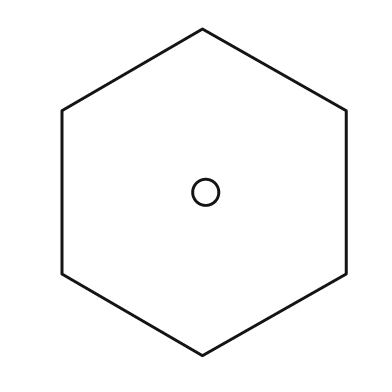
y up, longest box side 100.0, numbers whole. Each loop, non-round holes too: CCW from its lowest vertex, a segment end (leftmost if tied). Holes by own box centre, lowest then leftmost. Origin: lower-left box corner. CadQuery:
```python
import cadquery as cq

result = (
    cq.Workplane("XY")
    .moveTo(43.0, 0.0)
    .lineTo(87.0, 25.0)
    .lineTo(87.0, 75.0)
    .lineTo(43.0, 100.0)
    .lineTo(0.0, 75.0)
    .lineTo(0.0, 25.0)
    .close()
    .moveTo(44.0, 50.0)
    .circle(4.0)
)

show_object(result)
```